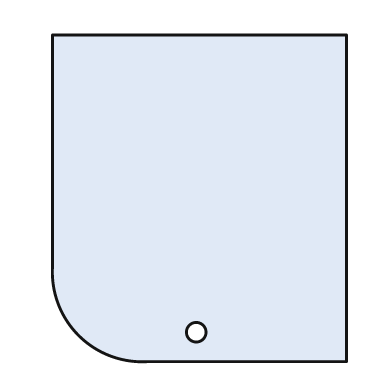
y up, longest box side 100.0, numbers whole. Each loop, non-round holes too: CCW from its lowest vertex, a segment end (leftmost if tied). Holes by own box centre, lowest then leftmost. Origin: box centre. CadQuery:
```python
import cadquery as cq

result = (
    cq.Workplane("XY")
    .moveTo(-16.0, -50.0)
    .lineTo(45.0, -50.0)
    .lineTo(45.0, 50.0)
    .lineTo(-45.0, 50.0)
    .lineTo(-45.0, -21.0)
    .threePointArc((-37.0, -42.0), (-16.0, -50.0))
    .close()
    .moveTo(-1.0, -41.0)
    .circle(3.0)
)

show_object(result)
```